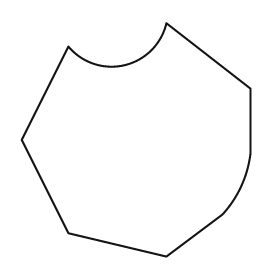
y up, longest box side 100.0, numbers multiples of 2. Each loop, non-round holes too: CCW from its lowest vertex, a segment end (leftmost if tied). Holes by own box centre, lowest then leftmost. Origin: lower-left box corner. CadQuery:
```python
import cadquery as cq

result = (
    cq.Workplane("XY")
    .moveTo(62.0, 0.0)
    .lineTo(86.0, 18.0)
    .threePointArc((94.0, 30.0), (98.0, 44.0))
    .lineTo(98.0, 72.0)
    .lineTo(62.0, 100.0)
    .threePointArc((44.0, 82.0), (20.0, 90.0))
    .lineTo(0.0, 50.0)
    .lineTo(20.0, 10.0)
    .close()
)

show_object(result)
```